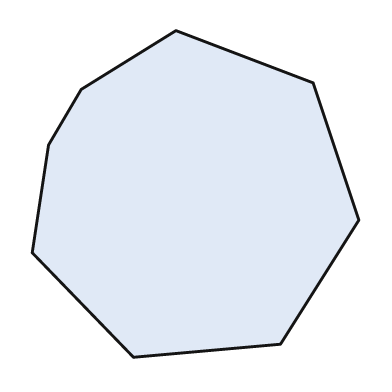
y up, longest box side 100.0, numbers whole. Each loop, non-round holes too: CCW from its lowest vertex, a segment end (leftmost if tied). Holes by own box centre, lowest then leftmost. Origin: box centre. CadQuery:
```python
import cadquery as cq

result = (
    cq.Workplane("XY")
    .moveTo(-19.0, -50.0)
    .lineTo(26.0, -46.0)
    .lineTo(50.0, -8.0)
    .lineTo(36.0, 34.0)
    .lineTo(-6.0, 50.0)
    .lineTo(-35.0, 32.0)
    .lineTo(-45.0, 15.0)
    .lineTo(-50.0, -18.0)
    .close()
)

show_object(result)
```